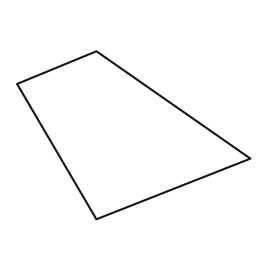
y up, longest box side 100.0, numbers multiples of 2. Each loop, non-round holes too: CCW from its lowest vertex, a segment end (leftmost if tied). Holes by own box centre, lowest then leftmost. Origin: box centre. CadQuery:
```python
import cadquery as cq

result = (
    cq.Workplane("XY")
    .moveTo(-16.0, -36.0)
    .lineTo(50.0, -10.0)
    .lineTo(-16.0, 36.0)
    .lineTo(-50.0, 22.0)
    .close()
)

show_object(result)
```